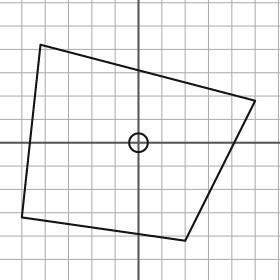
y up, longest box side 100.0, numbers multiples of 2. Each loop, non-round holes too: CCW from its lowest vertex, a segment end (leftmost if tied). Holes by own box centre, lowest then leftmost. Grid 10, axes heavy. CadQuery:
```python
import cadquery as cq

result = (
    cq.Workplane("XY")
    .moveTo(20.0, -42.0)
    .lineTo(50.0, 18.0)
    .lineTo(-42.0, 42.0)
    .lineTo(-50.0, -32.0)
    .close()
    .moveTo(0.0, 0.0)
    .circle(4.0)
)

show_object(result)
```